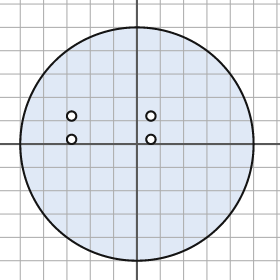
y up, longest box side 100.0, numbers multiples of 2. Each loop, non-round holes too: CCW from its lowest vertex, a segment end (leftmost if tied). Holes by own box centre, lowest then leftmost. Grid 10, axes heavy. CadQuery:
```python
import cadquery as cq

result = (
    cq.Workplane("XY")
    .moveTo(0.0, 0.0)
    .circle(50.0)
    .moveTo(-28.0, 2.0)
    .circle(2.0)
    .moveTo(6.0, 2.0)
    .circle(2.0)
    .moveTo(-28.0, 12.0)
    .circle(2.0)
    .moveTo(6.0, 12.0)
    .circle(2.0)
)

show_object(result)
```